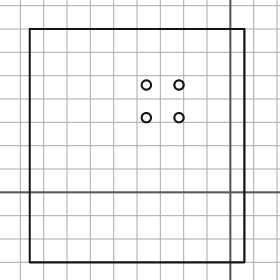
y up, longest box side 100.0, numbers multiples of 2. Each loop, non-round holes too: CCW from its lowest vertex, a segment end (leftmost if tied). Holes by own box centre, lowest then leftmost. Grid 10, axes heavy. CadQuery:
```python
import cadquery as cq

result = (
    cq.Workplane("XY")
    .moveTo(-86.0, -30.0)
    .lineTo(6.0, -30.0)
    .lineTo(6.0, 70.0)
    .lineTo(-86.0, 70.0)
    .close()
    .moveTo(-36.0, 32.0)
    .circle(2.0)
    .moveTo(-22.0, 32.0)
    .circle(2.0)
    .moveTo(-36.0, 46.0)
    .circle(2.0)
    .moveTo(-22.0, 46.0)
    .circle(2.0)
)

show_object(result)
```